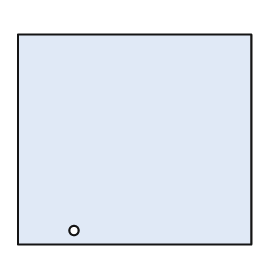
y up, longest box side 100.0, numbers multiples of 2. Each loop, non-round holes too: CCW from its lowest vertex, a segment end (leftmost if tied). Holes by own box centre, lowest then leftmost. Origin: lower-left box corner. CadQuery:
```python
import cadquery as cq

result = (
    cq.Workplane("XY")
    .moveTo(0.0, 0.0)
    .lineTo(100.0, 0.0)
    .lineTo(100.0, 90.0)
    .lineTo(0.0, 90.0)
    .close()
    .moveTo(24.0, 6.0)
    .circle(2.0)
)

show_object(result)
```